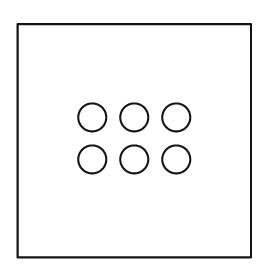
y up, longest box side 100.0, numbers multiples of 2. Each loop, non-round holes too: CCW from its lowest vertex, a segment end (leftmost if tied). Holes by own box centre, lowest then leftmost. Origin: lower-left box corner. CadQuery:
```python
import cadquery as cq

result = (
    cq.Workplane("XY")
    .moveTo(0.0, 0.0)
    .lineTo(100.0, 0.0)
    .lineTo(100.0, 100.0)
    .lineTo(0.0, 100.0)
    .close()
    .moveTo(32.0, 42.0)
    .circle(6.0)
    .moveTo(50.0, 42.0)
    .circle(6.0)
    .moveTo(68.0, 42.0)
    .circle(6.0)
    .moveTo(32.0, 60.0)
    .circle(6.0)
    .moveTo(50.0, 60.0)
    .circle(6.0)
    .moveTo(68.0, 60.0)
    .circle(6.0)
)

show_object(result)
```